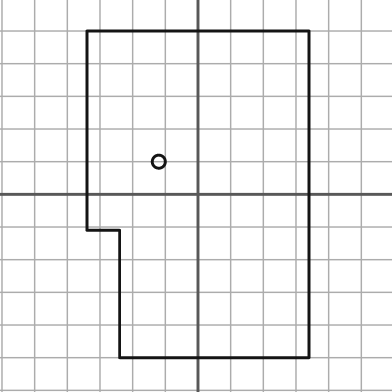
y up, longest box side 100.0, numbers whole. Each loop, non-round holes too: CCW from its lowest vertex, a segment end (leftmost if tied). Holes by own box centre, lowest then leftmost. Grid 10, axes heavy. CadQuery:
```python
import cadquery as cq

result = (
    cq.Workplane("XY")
    .moveTo(-24.0, -50.0)
    .lineTo(34.0, -50.0)
    .lineTo(34.0, 50.0)
    .lineTo(-34.0, 50.0)
    .lineTo(-34.0, -11.0)
    .lineTo(-24.0, -11.0)
    .close()
    .moveTo(-12.0, 10.0)
    .circle(2.0)
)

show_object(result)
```